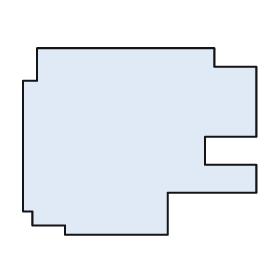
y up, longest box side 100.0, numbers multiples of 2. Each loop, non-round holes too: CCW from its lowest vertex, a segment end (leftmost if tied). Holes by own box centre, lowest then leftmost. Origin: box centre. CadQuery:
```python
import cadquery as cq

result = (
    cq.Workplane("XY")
    .moveTo(-32.0, -40.0)
    .lineTo(12.0, -40.0)
    .lineTo(12.0, -22.0)
    .lineTo(50.0, -22.0)
    .lineTo(50.0, -10.0)
    .lineTo(28.0, -10.0)
    .lineTo(28.0, 2.0)
    .lineTo(50.0, 2.0)
    .lineTo(50.0, 32.0)
    .lineTo(32.0, 32.0)
    .lineTo(32.0, 40.0)
    .lineTo(-44.0, 40.0)
    .lineTo(-44.0, 26.0)
    .lineTo(-50.0, 26.0)
    .lineTo(-50.0, -30.0)
    .lineTo(-46.0, -30.0)
    .lineTo(-46.0, -36.0)
    .lineTo(-32.0, -36.0)
    .close()
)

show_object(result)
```